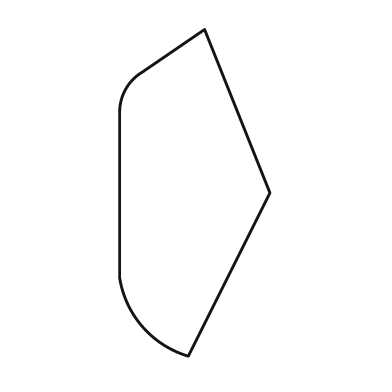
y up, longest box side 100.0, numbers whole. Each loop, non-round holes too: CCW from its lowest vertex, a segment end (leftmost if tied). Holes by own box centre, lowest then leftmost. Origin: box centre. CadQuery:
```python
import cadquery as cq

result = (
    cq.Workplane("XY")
    .moveTo(-2.0, -50.0)
    .lineTo(23.0, 0.0)
    .lineTo(3.0, 50.0)
    .lineTo(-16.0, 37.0)
    .threePointArc((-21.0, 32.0), (-23.0, 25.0))
    .lineTo(-23.0, -26.0)
    .threePointArc((-16.0, -41.0), (-2.0, -50.0))
    .close()
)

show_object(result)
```